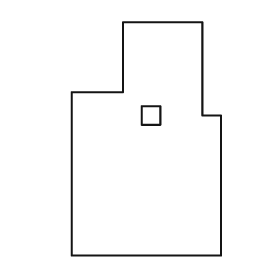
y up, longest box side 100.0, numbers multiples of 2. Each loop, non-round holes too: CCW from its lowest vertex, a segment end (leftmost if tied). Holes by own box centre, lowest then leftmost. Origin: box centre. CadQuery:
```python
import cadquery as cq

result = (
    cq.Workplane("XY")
    .moveTo(-32.0, -50.0)
    .lineTo(32.0, -50.0)
    .lineTo(32.0, 10.0)
    .lineTo(24.0, 10.0)
    .lineTo(24.0, 50.0)
    .lineTo(-10.0, 50.0)
    .lineTo(-10.0, 20.0)
    .lineTo(-32.0, 20.0)
    .close()
    .moveTo(-2.0, 6.0)
    .lineTo(6.0, 6.0)
    .lineTo(6.0, 14.0)
    .lineTo(-2.0, 14.0)
    .close()
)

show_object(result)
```